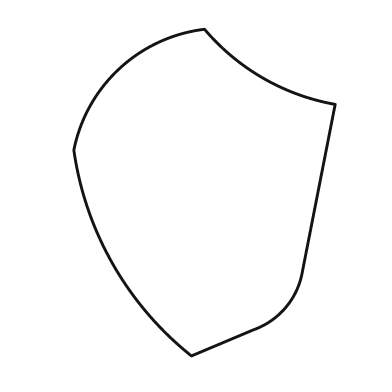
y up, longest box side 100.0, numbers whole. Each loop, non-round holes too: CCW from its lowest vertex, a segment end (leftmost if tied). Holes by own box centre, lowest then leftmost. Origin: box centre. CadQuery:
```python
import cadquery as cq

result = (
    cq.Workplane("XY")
    .moveTo(-4.0, -50.0)
    .lineTo(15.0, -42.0)
    .threePointArc((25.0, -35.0), (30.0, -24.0))
    .lineTo(40.0, 27.0)
    .threePointArc((18.0, 35.0), (0.0, 50.0))
    .threePointArc((-26.0, 38.0), (-40.0, 13.0))
    .threePointArc((-28.0, -22.0), (-4.0, -50.0))
    .close()
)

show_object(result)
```